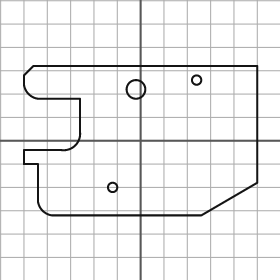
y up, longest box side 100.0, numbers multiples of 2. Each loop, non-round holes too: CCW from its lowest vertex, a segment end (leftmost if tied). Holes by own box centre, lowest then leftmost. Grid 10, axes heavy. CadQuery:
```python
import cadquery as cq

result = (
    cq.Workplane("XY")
    .moveTo(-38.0, -32.0)
    .lineTo(26.0, -32.0)
    .lineTo(50.0, -18.0)
    .lineTo(50.0, 32.0)
    .lineTo(-46.0, 32.0)
    .lineTo(-50.0, 28.0)
    .lineTo(-50.0, 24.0)
    .threePointArc((-48.0, 20.0), (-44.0, 18.0))
    .lineTo(-26.0, 18.0)
    .lineTo(-26.0, 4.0)
    .threePointArc((-28.0, -2.0), (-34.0, -4.0))
    .lineTo(-50.0, -4.0)
    .lineTo(-50.0, -10.0)
    .lineTo(-44.0, -10.0)
    .lineTo(-44.0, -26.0)
    .threePointArc((-42.0, -30.0), (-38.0, -32.0))
    .close()
    .moveTo(-12.0, -20.0)
    .circle(2.0)
    .moveTo(-2.0, 22.0)
    .circle(4.0)
    .moveTo(24.0, 26.0)
    .circle(2.0)
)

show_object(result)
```